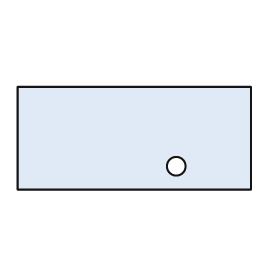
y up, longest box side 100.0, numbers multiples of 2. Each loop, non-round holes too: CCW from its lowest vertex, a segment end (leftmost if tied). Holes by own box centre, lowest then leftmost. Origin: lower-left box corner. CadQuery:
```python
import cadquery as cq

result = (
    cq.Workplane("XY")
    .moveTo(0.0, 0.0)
    .lineTo(100.0, 0.0)
    .lineTo(100.0, 44.0)
    .lineTo(0.0, 44.0)
    .close()
    .moveTo(68.0, 10.0)
    .circle(4.0)
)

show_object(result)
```